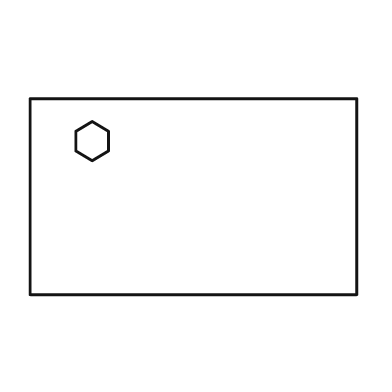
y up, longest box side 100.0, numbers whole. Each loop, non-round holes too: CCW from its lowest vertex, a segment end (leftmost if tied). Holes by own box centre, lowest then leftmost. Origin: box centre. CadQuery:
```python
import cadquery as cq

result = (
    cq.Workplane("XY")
    .moveTo(-50.0, -30.0)
    .lineTo(50.0, -30.0)
    .lineTo(50.0, 30.0)
    .lineTo(-50.0, 30.0)
    .close()
    .moveTo(-31.0, 11.0)
    .lineTo(-26.0, 14.0)
    .lineTo(-26.0, 20.0)
    .lineTo(-31.0, 23.0)
    .lineTo(-36.0, 20.0)
    .lineTo(-36.0, 14.0)
    .close()
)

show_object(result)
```